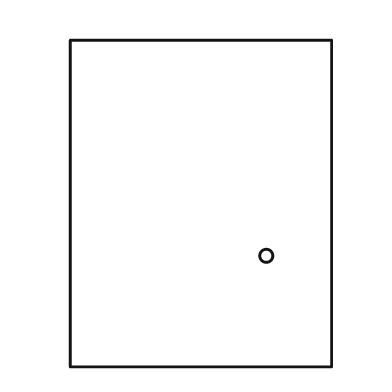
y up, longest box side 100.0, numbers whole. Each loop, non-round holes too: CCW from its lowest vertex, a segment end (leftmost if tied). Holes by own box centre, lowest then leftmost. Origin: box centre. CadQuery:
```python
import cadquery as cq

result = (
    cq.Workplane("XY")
    .moveTo(-40.0, -50.0)
    .lineTo(40.0, -50.0)
    .lineTo(40.0, 50.0)
    .lineTo(-40.0, 50.0)
    .close()
    .moveTo(20.0, -16.0)
    .circle(2.0)
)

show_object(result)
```